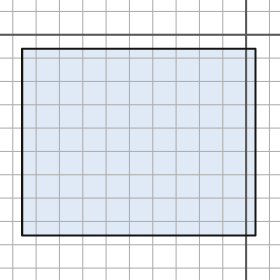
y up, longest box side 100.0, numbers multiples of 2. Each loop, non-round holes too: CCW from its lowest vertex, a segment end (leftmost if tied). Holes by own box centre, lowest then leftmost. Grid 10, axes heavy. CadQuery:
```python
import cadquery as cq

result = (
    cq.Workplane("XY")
    .moveTo(-96.0, -86.0)
    .lineTo(4.0, -86.0)
    .lineTo(4.0, -6.0)
    .lineTo(-96.0, -6.0)
    .close()
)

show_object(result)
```